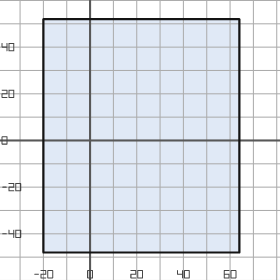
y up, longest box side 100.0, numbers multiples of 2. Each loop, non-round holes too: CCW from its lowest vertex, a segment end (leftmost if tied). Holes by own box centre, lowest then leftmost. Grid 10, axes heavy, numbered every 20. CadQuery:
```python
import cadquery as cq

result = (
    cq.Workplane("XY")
    .moveTo(-20.0, -48.0)
    .lineTo(64.0, -48.0)
    .lineTo(64.0, 52.0)
    .lineTo(-20.0, 52.0)
    .close()
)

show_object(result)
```